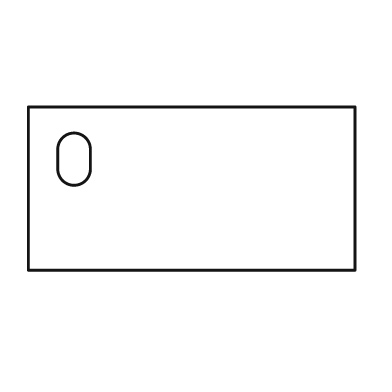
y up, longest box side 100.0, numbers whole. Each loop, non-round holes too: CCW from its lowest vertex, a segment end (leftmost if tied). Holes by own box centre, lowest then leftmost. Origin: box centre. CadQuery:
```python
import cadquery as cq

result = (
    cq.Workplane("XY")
    .moveTo(-50.0, -25.0)
    .lineTo(50.0, -25.0)
    .lineTo(50.0, 25.0)
    .lineTo(-50.0, 25.0)
    .close()
    .moveTo(-41.0, 6.0)
    .threePointArc((-36.0, 1.0), (-31.0, 6.0))
    .lineTo(-31.0, 12.0)
    .threePointArc((-36.0, 17.0), (-41.0, 12.0))
    .close()
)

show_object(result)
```